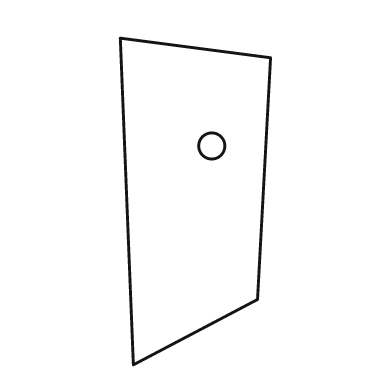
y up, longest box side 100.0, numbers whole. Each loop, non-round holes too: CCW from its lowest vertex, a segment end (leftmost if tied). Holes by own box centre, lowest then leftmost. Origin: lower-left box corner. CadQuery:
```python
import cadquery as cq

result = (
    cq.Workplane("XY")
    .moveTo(4.0, 0.0)
    .lineTo(42.0, 20.0)
    .lineTo(46.0, 94.0)
    .lineTo(0.0, 100.0)
    .close()
    .moveTo(28.0, 67.0)
    .circle(4.0)
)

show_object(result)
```